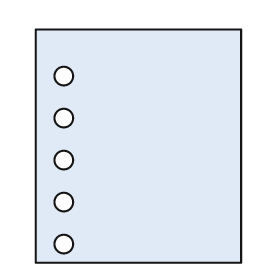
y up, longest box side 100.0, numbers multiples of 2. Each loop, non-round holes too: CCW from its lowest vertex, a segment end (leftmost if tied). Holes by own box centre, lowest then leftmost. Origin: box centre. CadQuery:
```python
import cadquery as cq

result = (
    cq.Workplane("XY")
    .moveTo(-44.0, -50.0)
    .lineTo(44.0, -50.0)
    .lineTo(44.0, 50.0)
    .lineTo(-44.0, 50.0)
    .close()
    .moveTo(-32.0, -42.0)
    .circle(4.0)
    .moveTo(-32.0, -24.0)
    .circle(4.0)
    .moveTo(-32.0, -6.0)
    .circle(4.0)
    .moveTo(-32.0, 12.0)
    .circle(4.0)
    .moveTo(-32.0, 30.0)
    .circle(4.0)
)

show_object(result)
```